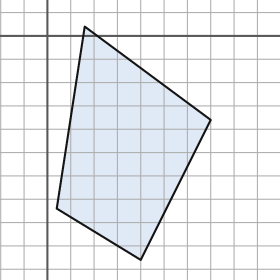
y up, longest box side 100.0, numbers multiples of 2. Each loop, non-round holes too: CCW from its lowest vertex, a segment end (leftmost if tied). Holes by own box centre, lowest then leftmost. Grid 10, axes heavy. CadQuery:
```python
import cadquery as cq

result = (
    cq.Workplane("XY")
    .moveTo(40.0, -96.0)
    .lineTo(70.0, -36.0)
    .lineTo(16.0, 4.0)
    .lineTo(4.0, -74.0)
    .close()
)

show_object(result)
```